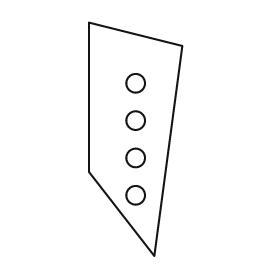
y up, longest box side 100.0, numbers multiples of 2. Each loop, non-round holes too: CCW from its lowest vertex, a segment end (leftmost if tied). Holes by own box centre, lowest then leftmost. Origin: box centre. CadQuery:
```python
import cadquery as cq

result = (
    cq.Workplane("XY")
    .moveTo(8.0, -50.0)
    .lineTo(20.0, 40.0)
    .lineTo(-20.0, 50.0)
    .lineTo(-20.0, -14.0)
    .close()
    .moveTo(0.0, -24.0)
    .circle(4.0)
    .moveTo(0.0, -8.0)
    .circle(4.0)
    .moveTo(0.0, 8.0)
    .circle(4.0)
    .moveTo(0.0, 24.0)
    .circle(4.0)
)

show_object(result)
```